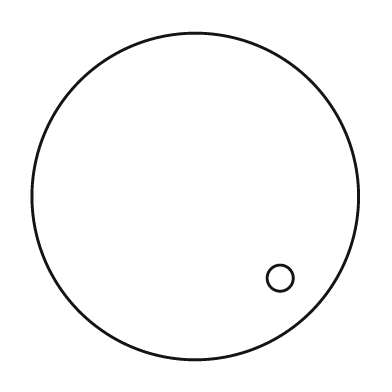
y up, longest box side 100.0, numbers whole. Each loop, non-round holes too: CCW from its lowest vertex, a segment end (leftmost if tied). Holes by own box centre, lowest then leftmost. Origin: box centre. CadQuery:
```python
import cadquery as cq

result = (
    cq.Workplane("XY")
    .moveTo(0.0, 0.0)
    .circle(50.0)
    .moveTo(26.0, -25.0)
    .circle(4.0)
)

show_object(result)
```